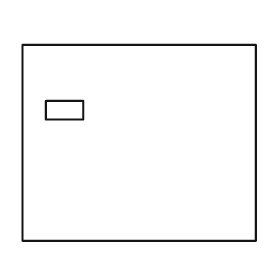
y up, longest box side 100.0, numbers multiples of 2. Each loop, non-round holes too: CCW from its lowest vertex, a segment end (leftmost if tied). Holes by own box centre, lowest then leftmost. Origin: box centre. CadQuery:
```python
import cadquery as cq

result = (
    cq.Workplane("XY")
    .moveTo(-50.0, -42.0)
    .lineTo(50.0, -42.0)
    .lineTo(50.0, 42.0)
    .lineTo(-50.0, 42.0)
    .close()
    .moveTo(-40.0, 10.0)
    .lineTo(-24.0, 10.0)
    .lineTo(-24.0, 18.0)
    .lineTo(-40.0, 18.0)
    .close()
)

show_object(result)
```